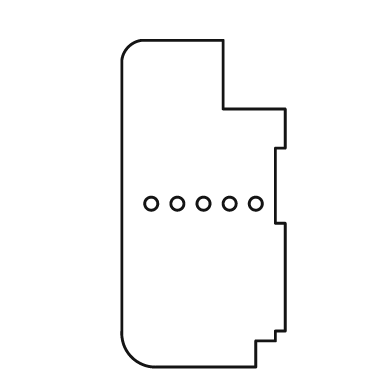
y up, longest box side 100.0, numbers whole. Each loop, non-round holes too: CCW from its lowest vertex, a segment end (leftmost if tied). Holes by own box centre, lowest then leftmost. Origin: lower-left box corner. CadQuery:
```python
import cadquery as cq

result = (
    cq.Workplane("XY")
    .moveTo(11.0, 0.0)
    .lineTo(41.0, 0.0)
    .lineTo(41.0, 8.0)
    .lineTo(47.0, 8.0)
    .lineTo(47.0, 11.0)
    .lineTo(50.0, 11.0)
    .lineTo(50.0, 44.0)
    .lineTo(47.0, 44.0)
    .lineTo(47.0, 67.0)
    .lineTo(50.0, 67.0)
    .lineTo(50.0, 79.0)
    .lineTo(31.0, 79.0)
    .lineTo(31.0, 100.0)
    .lineTo(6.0, 100.0)
    .threePointArc((2.0, 98.0), (0.0, 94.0))
    .lineTo(0.0, 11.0)
    .threePointArc((3.0, 3.0), (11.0, 0.0))
    .close()
    .moveTo(9.0, 50.0)
    .circle(2.0)
    .moveTo(17.0, 50.0)
    .circle(2.0)
    .moveTo(25.0, 50.0)
    .circle(2.0)
    .moveTo(33.0, 50.0)
    .circle(2.0)
    .moveTo(41.0, 50.0)
    .circle(2.0)
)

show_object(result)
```